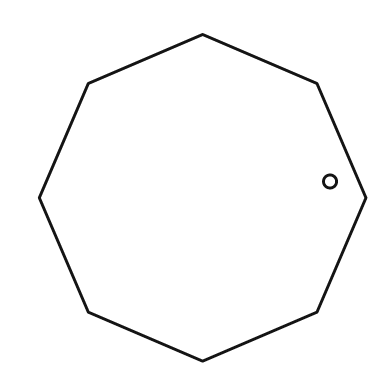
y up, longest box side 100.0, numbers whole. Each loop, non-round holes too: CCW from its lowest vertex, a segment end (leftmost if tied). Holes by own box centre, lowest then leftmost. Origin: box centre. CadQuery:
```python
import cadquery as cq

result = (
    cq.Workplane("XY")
    .moveTo(0.0, -50.0)
    .lineTo(35.0, -35.0)
    .lineTo(50.0, 0.0)
    .lineTo(35.0, 35.0)
    .lineTo(0.0, 50.0)
    .lineTo(-35.0, 35.0)
    .lineTo(-50.0, 0.0)
    .lineTo(-35.0, -35.0)
    .close()
    .moveTo(39.0, 5.0)
    .circle(2.0)
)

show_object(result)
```